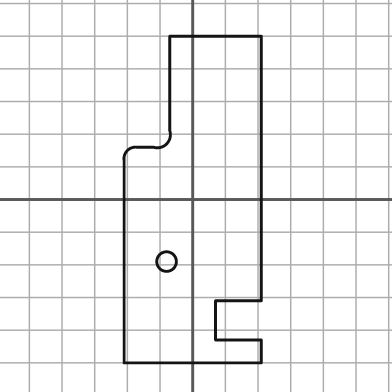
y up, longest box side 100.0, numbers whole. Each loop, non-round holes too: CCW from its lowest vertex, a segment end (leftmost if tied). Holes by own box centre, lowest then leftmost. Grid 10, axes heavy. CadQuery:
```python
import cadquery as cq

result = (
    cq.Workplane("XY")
    .moveTo(-21.0, -50.0)
    .lineTo(21.0, -50.0)
    .lineTo(21.0, -43.0)
    .lineTo(7.0, -43.0)
    .lineTo(7.0, -31.0)
    .lineTo(21.0, -31.0)
    .lineTo(21.0, 50.0)
    .lineTo(-7.0, 50.0)
    .lineTo(-7.0, 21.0)
    .threePointArc((-8.0, 17.0), (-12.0, 16.0))
    .lineTo(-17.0, 16.0)
    .threePointArc((-20.0, 15.0), (-21.0, 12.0))
    .close()
    .moveTo(-8.0, -19.0)
    .circle(3.0)
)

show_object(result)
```